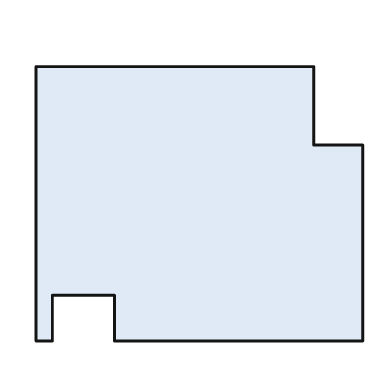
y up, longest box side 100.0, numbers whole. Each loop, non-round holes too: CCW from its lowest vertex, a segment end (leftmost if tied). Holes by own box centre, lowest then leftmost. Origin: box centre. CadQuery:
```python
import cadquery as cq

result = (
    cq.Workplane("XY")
    .moveTo(-50.0, -42.0)
    .lineTo(-45.0, -42.0)
    .lineTo(-45.0, -28.0)
    .lineTo(-26.0, -28.0)
    .lineTo(-26.0, -42.0)
    .lineTo(50.0, -42.0)
    .lineTo(50.0, 18.0)
    .lineTo(35.0, 18.0)
    .lineTo(35.0, 42.0)
    .lineTo(-50.0, 42.0)
    .close()
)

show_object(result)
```